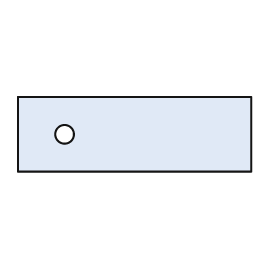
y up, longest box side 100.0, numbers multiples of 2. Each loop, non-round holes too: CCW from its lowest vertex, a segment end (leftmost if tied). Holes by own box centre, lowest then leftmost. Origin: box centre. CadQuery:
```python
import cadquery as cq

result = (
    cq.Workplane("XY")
    .moveTo(-50.0, -16.0)
    .lineTo(50.0, -16.0)
    .lineTo(50.0, 16.0)
    .lineTo(-50.0, 16.0)
    .close()
    .moveTo(-30.0, 0.0)
    .circle(4.0)
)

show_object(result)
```